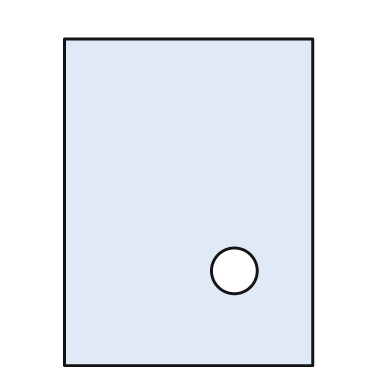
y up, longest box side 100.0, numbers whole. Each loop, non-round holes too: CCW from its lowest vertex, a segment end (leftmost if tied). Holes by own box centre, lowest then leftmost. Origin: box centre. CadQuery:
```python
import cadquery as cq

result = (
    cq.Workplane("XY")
    .moveTo(-38.0, -50.0)
    .lineTo(38.0, -50.0)
    .lineTo(38.0, 50.0)
    .lineTo(-38.0, 50.0)
    .close()
    .moveTo(14.0, -21.0)
    .circle(7.0)
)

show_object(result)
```